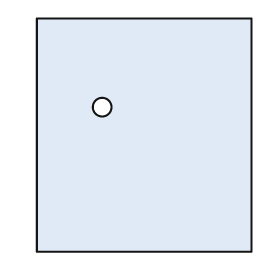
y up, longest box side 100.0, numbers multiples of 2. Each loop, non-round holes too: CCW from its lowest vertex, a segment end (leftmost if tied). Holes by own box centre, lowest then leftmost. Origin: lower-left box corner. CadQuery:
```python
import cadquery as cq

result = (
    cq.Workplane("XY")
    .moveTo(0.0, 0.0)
    .lineTo(92.0, 0.0)
    .lineTo(92.0, 100.0)
    .lineTo(0.0, 100.0)
    .close()
    .moveTo(28.0, 62.0)
    .circle(4.0)
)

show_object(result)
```